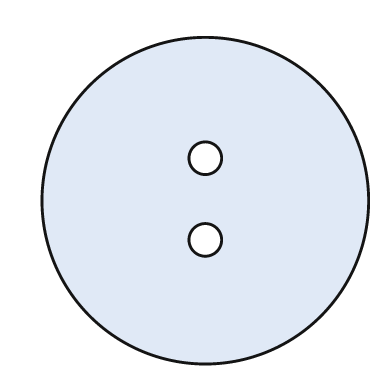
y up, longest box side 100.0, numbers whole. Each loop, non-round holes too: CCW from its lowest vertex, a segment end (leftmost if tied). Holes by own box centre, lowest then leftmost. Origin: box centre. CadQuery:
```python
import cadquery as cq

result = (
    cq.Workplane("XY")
    .moveTo(0.0, 0.0)
    .circle(50.0)
    .moveTo(0.0, -12.0)
    .circle(5.0)
    .moveTo(0.0, 13.0)
    .circle(5.0)
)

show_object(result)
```